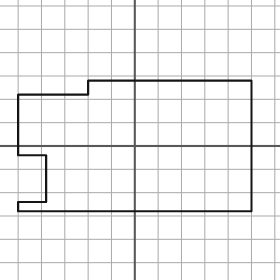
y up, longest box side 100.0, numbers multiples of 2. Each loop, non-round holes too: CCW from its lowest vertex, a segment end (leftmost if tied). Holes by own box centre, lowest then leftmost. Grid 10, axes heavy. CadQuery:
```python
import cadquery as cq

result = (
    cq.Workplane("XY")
    .moveTo(-50.0, -28.0)
    .lineTo(50.0, -28.0)
    .lineTo(50.0, 28.0)
    .lineTo(-20.0, 28.0)
    .lineTo(-20.0, 22.0)
    .lineTo(-50.0, 22.0)
    .lineTo(-50.0, -4.0)
    .lineTo(-38.0, -4.0)
    .lineTo(-38.0, -24.0)
    .lineTo(-50.0, -24.0)
    .close()
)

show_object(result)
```